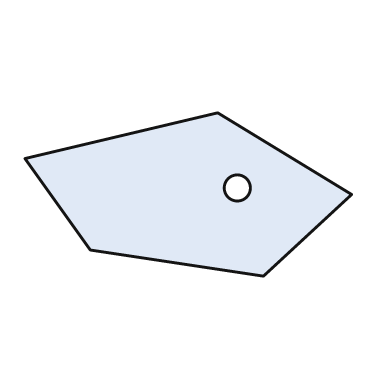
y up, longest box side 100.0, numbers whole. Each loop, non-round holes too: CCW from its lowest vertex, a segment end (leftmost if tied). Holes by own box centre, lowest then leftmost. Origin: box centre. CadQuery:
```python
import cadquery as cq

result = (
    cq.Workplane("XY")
    .moveTo(23.0, -25.0)
    .lineTo(50.0, 0.0)
    .lineTo(9.0, 25.0)
    .lineTo(-50.0, 11.0)
    .lineTo(-30.0, -17.0)
    .close()
    .moveTo(15.0, 2.0)
    .circle(4.0)
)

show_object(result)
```